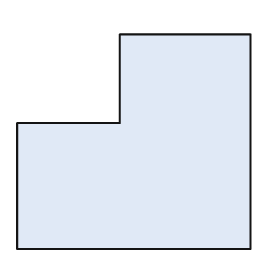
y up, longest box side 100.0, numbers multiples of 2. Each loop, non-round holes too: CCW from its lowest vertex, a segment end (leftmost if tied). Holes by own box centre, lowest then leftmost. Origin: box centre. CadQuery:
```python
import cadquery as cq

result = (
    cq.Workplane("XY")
    .moveTo(-50.0, -46.0)
    .lineTo(50.0, -46.0)
    .lineTo(50.0, 46.0)
    .lineTo(-6.0, 46.0)
    .lineTo(-6.0, 8.0)
    .lineTo(-50.0, 8.0)
    .close()
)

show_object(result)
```